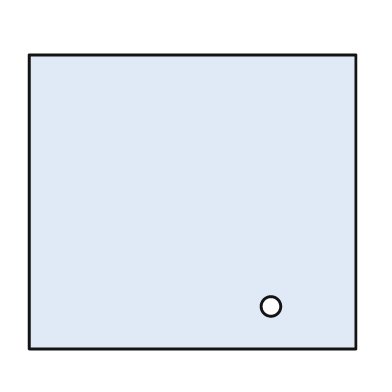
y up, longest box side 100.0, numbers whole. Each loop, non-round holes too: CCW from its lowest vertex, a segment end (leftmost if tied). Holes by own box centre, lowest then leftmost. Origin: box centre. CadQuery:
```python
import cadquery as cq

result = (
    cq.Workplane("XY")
    .moveTo(-50.0, -45.0)
    .lineTo(50.0, -45.0)
    .lineTo(50.0, 45.0)
    .lineTo(-50.0, 45.0)
    .close()
    .moveTo(24.0, -32.0)
    .circle(3.0)
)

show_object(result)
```